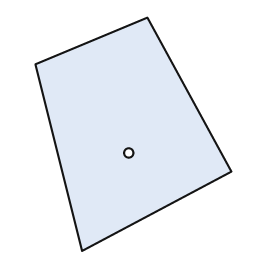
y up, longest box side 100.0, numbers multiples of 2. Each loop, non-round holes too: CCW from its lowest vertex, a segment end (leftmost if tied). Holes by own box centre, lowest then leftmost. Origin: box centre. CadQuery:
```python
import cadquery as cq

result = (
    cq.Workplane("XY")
    .moveTo(-22.0, -50.0)
    .lineTo(42.0, -16.0)
    .lineTo(6.0, 50.0)
    .lineTo(-42.0, 30.0)
    .close()
    .moveTo(-2.0, -8.0)
    .circle(2.0)
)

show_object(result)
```